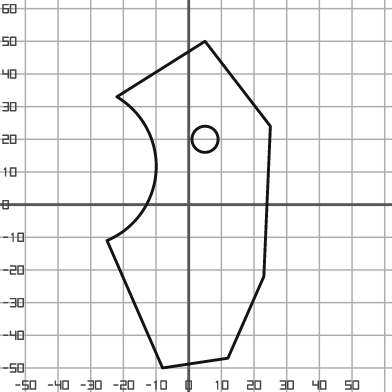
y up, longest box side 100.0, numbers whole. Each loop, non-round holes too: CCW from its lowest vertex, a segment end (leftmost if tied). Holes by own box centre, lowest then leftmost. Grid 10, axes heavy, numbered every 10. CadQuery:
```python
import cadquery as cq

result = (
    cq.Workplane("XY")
    .moveTo(-8.0, -50.0)
    .lineTo(12.0, -47.0)
    .lineTo(23.0, -22.0)
    .lineTo(25.0, 24.0)
    .lineTo(5.0, 50.0)
    .lineTo(-22.0, 33.0)
    .threePointArc((-10.0, 10.0), (-25.0, -11.0))
    .close()
    .moveTo(5.0, 20.0)
    .circle(4.0)
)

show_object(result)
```